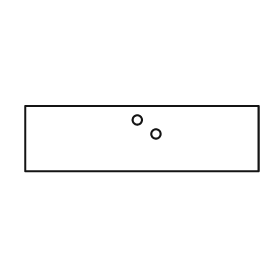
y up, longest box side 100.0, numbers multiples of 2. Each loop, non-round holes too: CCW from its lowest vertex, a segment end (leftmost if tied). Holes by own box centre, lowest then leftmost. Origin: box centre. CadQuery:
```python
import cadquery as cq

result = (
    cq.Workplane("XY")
    .moveTo(-50.0, -14.0)
    .lineTo(50.0, -14.0)
    .lineTo(50.0, 14.0)
    .lineTo(-50.0, 14.0)
    .close()
    .moveTo(6.0, 2.0)
    .circle(2.0)
    .moveTo(-2.0, 8.0)
    .circle(2.0)
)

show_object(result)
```